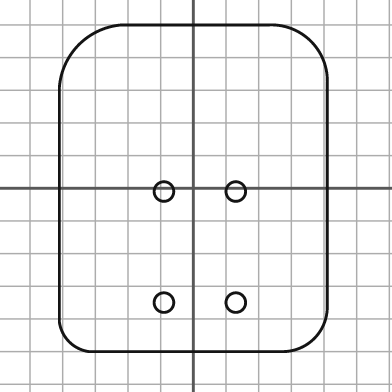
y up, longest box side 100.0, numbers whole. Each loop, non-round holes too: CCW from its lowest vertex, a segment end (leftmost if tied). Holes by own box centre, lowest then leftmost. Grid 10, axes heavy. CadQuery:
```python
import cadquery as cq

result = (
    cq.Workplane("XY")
    .moveTo(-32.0, -50.0)
    .lineTo(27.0, -50.0)
    .threePointArc((37.0, -46.0), (41.0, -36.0))
    .lineTo(41.0, 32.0)
    .threePointArc((36.0, 45.0), (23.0, 50.0))
    .lineTo(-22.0, 50.0)
    .threePointArc((-35.0, 44.0), (-41.0, 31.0))
    .lineTo(-41.0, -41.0)
    .threePointArc((-38.0, -47.0), (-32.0, -50.0))
    .close()
    .moveTo(-9.0, -35.0)
    .circle(3.0)
    .moveTo(13.0, -35.0)
    .circle(3.0)
    .moveTo(-9.0, -1.0)
    .circle(3.0)
    .moveTo(13.0, -1.0)
    .circle(3.0)
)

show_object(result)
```